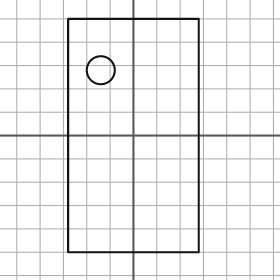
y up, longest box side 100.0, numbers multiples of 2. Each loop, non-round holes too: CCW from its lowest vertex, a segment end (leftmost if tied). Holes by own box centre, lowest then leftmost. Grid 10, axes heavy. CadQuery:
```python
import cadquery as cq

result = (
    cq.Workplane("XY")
    .moveTo(-28.0, -50.0)
    .lineTo(28.0, -50.0)
    .lineTo(28.0, 50.0)
    .lineTo(-28.0, 50.0)
    .close()
    .moveTo(-14.0, 28.0)
    .circle(6.0)
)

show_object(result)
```